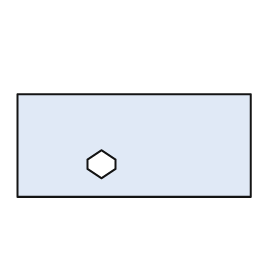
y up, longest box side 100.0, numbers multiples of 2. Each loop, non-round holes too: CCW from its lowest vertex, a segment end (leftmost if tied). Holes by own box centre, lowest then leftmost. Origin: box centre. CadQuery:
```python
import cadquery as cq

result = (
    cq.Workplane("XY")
    .moveTo(-50.0, -22.0)
    .lineTo(50.0, -22.0)
    .lineTo(50.0, 22.0)
    .lineTo(-50.0, 22.0)
    .close()
    .moveTo(-14.0, -14.0)
    .lineTo(-8.0, -10.0)
    .lineTo(-8.0, -6.0)
    .lineTo(-14.0, -2.0)
    .lineTo(-20.0, -6.0)
    .lineTo(-20.0, -10.0)
    .close()
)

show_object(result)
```